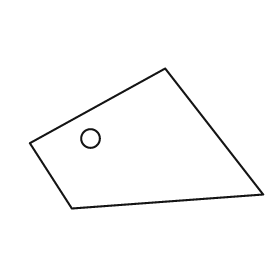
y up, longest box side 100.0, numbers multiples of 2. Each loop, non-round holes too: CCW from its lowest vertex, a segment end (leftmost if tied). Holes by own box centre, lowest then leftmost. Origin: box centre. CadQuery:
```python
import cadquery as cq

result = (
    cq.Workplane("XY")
    .moveTo(-32.0, -30.0)
    .lineTo(50.0, -24.0)
    .lineTo(8.0, 30.0)
    .lineTo(-50.0, -2.0)
    .close()
    .moveTo(-24.0, 0.0)
    .circle(4.0)
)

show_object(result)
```